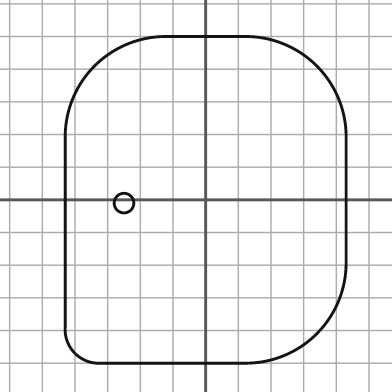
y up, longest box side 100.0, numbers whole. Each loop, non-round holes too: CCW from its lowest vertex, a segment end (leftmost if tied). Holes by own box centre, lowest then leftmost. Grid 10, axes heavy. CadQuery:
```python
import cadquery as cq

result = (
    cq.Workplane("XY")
    .moveTo(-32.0, -50.0)
    .lineTo(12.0, -50.0)
    .threePointArc((34.0, -41.0), (43.0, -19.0))
    .lineTo(43.0, 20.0)
    .threePointArc((34.0, 41.0), (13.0, 50.0))
    .lineTo(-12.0, 50.0)
    .threePointArc((-34.0, 41.0), (-43.0, 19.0))
    .lineTo(-43.0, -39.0)
    .threePointArc((-40.0, -47.0), (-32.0, -50.0))
    .close()
    .moveTo(-25.0, -1.0)
    .circle(3.0)
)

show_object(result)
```